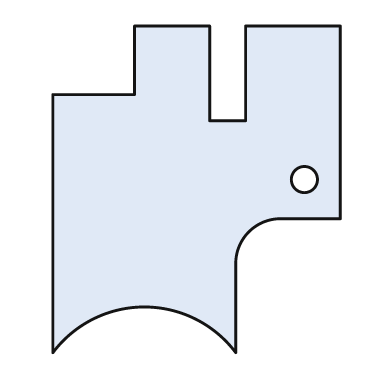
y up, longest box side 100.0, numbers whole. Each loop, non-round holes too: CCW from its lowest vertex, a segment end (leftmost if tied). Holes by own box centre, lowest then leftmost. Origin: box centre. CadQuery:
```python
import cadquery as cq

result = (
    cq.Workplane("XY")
    .moveTo(-44.0, -50.0)
    .threePointArc((-16.0, -36.0), (12.0, -50.0))
    .lineTo(12.0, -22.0)
    .threePointArc((16.0, -13.0), (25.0, -9.0))
    .lineTo(44.0, -9.0)
    .lineTo(44.0, 50.0)
    .lineTo(15.0, 50.0)
    .lineTo(15.0, 21.0)
    .lineTo(4.0, 21.0)
    .lineTo(4.0, 50.0)
    .lineTo(-19.0, 50.0)
    .lineTo(-19.0, 29.0)
    .lineTo(-44.0, 29.0)
    .close()
    .moveTo(33.0, 3.0)
    .circle(4.0)
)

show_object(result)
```